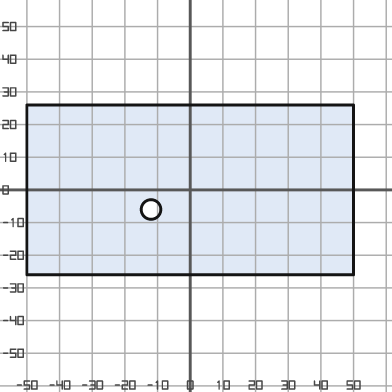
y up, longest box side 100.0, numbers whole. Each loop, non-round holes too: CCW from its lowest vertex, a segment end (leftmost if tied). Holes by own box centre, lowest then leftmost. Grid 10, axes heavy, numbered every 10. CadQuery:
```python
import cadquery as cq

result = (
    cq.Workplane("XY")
    .moveTo(-50.0, -26.0)
    .lineTo(50.0, -26.0)
    .lineTo(50.0, 26.0)
    .lineTo(-50.0, 26.0)
    .close()
    .moveTo(-12.0, -6.0)
    .circle(3.0)
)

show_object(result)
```